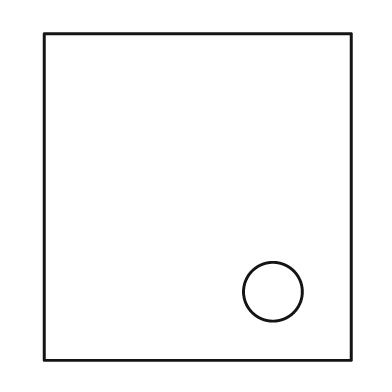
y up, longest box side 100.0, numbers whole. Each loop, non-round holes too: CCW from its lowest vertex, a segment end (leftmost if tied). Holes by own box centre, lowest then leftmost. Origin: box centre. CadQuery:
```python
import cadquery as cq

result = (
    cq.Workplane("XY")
    .moveTo(-47.0, -50.0)
    .lineTo(47.0, -50.0)
    .lineTo(47.0, 50.0)
    .lineTo(-47.0, 50.0)
    .close()
    .moveTo(23.0, -29.0)
    .circle(9.0)
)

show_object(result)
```